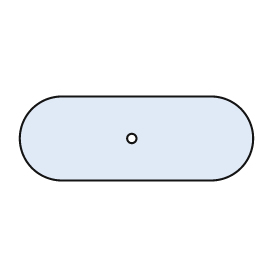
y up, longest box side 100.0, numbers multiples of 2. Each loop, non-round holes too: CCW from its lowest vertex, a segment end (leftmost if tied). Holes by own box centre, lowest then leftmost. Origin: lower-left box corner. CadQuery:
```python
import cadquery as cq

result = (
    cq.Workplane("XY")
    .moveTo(18.0, 0.0)
    .lineTo(82.0, 0.0)
    .threePointArc((100.0, 18.0), (82.0, 36.0))
    .lineTo(18.0, 36.0)
    .threePointArc((0.0, 18.0), (18.0, 0.0))
    .close()
    .moveTo(48.0, 18.0)
    .circle(2.0)
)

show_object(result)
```